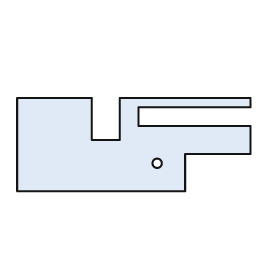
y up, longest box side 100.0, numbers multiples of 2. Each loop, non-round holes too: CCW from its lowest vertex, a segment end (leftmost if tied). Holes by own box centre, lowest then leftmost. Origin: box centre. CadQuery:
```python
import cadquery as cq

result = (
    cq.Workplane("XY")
    .moveTo(-50.0, -20.0)
    .lineTo(22.0, -20.0)
    .lineTo(22.0, -4.0)
    .lineTo(50.0, -4.0)
    .lineTo(50.0, 8.0)
    .lineTo(2.0, 8.0)
    .lineTo(2.0, 16.0)
    .lineTo(50.0, 16.0)
    .lineTo(50.0, 20.0)
    .lineTo(-6.0, 20.0)
    .lineTo(-6.0, 2.0)
    .lineTo(-18.0, 2.0)
    .lineTo(-18.0, 20.0)
    .lineTo(-50.0, 20.0)
    .close()
    .moveTo(10.0, -8.0)
    .circle(2.0)
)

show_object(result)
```